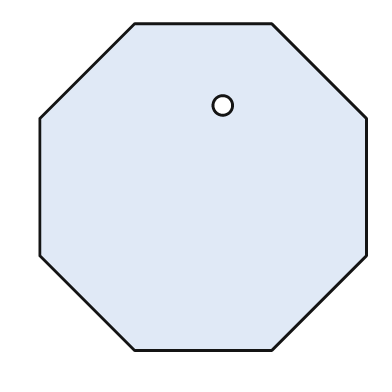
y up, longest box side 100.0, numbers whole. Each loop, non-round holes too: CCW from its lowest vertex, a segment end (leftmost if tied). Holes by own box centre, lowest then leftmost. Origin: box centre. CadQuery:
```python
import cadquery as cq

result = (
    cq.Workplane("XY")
    .moveTo(-21.0, -50.0)
    .lineTo(21.0, -50.0)
    .lineTo(50.0, -21.0)
    .lineTo(50.0, 21.0)
    .lineTo(21.0, 50.0)
    .lineTo(-21.0, 50.0)
    .lineTo(-50.0, 21.0)
    .lineTo(-50.0, -21.0)
    .close()
    .moveTo(6.0, 25.0)
    .circle(3.0)
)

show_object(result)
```